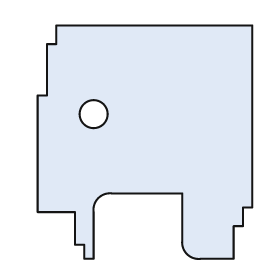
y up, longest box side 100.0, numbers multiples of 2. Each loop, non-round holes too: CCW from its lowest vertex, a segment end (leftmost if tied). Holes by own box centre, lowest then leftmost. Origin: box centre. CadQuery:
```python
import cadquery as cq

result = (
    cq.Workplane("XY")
    .moveTo(-26.0, -50.0)
    .lineTo(-22.0, -50.0)
    .lineTo(-22.0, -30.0)
    .threePointArc((-20.0, -24.0), (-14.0, -22.0))
    .lineTo(16.0, -22.0)
    .lineTo(16.0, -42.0)
    .threePointArc((18.0, -48.0), (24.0, -50.0))
    .lineTo(38.0, -50.0)
    .lineTo(38.0, -36.0)
    .lineTo(42.0, -36.0)
    .lineTo(42.0, -28.0)
    .lineTo(46.0, -28.0)
    .lineTo(46.0, 50.0)
    .lineTo(-38.0, 50.0)
    .lineTo(-38.0, 42.0)
    .lineTo(-42.0, 42.0)
    .lineTo(-42.0, 20.0)
    .lineTo(-46.0, 20.0)
    .lineTo(-46.0, -30.0)
    .lineTo(-30.0, -30.0)
    .lineTo(-30.0, -44.0)
    .lineTo(-26.0, -44.0)
    .close()
    .moveTo(-22.0, 12.0)
    .circle(6.0)
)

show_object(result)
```